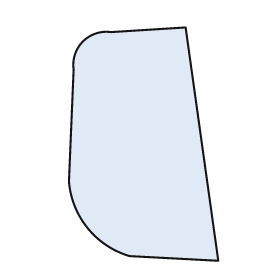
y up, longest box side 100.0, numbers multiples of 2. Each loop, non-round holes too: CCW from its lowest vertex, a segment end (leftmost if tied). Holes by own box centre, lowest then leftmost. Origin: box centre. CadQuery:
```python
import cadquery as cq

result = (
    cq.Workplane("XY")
    .moveTo(32.0, -50.0)
    .lineTo(18.0, 50.0)
    .lineTo(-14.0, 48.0)
    .threePointArc((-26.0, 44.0), (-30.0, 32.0))
    .lineTo(-32.0, -16.0)
    .threePointArc((-24.0, -36.0), (-6.0, -48.0))
    .close()
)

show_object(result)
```